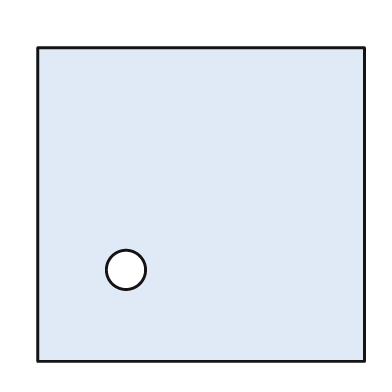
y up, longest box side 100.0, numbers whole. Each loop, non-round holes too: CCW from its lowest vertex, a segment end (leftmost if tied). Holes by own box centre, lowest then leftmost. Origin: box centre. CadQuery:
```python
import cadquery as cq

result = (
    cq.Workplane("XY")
    .moveTo(-50.0, -48.0)
    .lineTo(50.0, -48.0)
    .lineTo(50.0, 48.0)
    .lineTo(-50.0, 48.0)
    .close()
    .moveTo(-23.0, -20.0)
    .circle(6.0)
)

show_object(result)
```